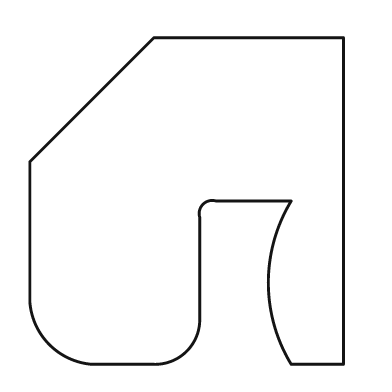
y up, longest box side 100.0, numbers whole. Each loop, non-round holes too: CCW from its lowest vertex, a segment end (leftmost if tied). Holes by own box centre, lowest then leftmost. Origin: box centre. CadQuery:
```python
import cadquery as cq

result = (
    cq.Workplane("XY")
    .moveTo(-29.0, -50.0)
    .lineTo(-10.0, -50.0)
    .threePointArc((0.0, -46.0), (4.0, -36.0))
    .lineTo(4.0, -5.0)
    .threePointArc((5.0, -1.0), (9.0, 0.0))
    .lineTo(32.0, 0.0)
    .threePointArc((25.0, -25.0), (32.0, -50.0))
    .lineTo(48.0, -50.0)
    .lineTo(48.0, 50.0)
    .lineTo(-10.0, 50.0)
    .lineTo(-48.0, 12.0)
    .lineTo(-48.0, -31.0)
    .threePointArc((-42.0, -44.0), (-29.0, -50.0))
    .close()
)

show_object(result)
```